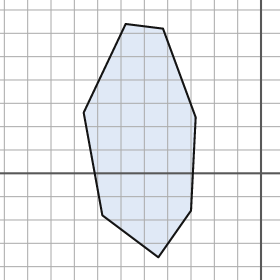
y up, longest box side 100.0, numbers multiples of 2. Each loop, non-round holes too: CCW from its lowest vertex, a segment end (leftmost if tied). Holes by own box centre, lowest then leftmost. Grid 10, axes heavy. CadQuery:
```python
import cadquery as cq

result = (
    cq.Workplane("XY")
    .moveTo(-44.0, -36.0)
    .lineTo(-30.0, -16.0)
    .lineTo(-28.0, 24.0)
    .lineTo(-42.0, 62.0)
    .lineTo(-58.0, 64.0)
    .lineTo(-76.0, 26.0)
    .lineTo(-68.0, -18.0)
    .close()
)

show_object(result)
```